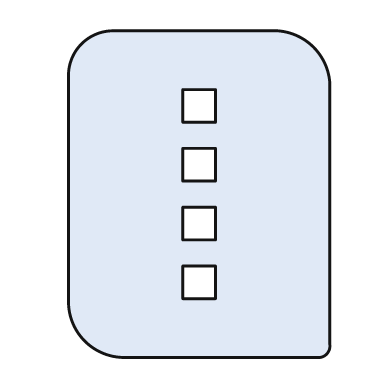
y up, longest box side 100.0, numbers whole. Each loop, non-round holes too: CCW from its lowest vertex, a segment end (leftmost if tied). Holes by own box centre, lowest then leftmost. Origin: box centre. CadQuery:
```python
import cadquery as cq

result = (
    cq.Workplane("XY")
    .moveTo(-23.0, -50.0)
    .lineTo(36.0, -50.0)
    .threePointArc((39.0, -49.0), (40.0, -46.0))
    .lineTo(40.0, 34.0)
    .threePointArc((35.0, 45.0), (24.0, 50.0))
    .lineTo(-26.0, 50.0)
    .threePointArc((-36.0, 46.0), (-40.0, 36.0))
    .lineTo(-40.0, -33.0)
    .threePointArc((-35.0, -45.0), (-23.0, -50.0))
    .close()
    .moveTo(-5.0, -32.0)
    .lineTo(5.0, -32.0)
    .lineTo(5.0, -22.0)
    .lineTo(-5.0, -22.0)
    .close()
    .moveTo(-5.0, -14.0)
    .lineTo(5.0, -14.0)
    .lineTo(5.0, -4.0)
    .lineTo(-5.0, -4.0)
    .close()
    .moveTo(-5.0, 4.0)
    .lineTo(5.0, 4.0)
    .lineTo(5.0, 14.0)
    .lineTo(-5.0, 14.0)
    .close()
    .moveTo(-5.0, 22.0)
    .lineTo(5.0, 22.0)
    .lineTo(5.0, 32.0)
    .lineTo(-5.0, 32.0)
    .close()
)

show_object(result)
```